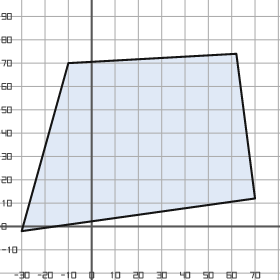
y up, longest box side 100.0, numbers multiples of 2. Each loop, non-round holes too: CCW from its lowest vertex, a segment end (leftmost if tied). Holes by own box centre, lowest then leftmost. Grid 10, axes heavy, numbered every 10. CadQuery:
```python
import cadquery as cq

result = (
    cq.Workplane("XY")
    .moveTo(-30.0, -2.0)
    .lineTo(70.0, 12.0)
    .lineTo(62.0, 74.0)
    .lineTo(-10.0, 70.0)
    .close()
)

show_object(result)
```